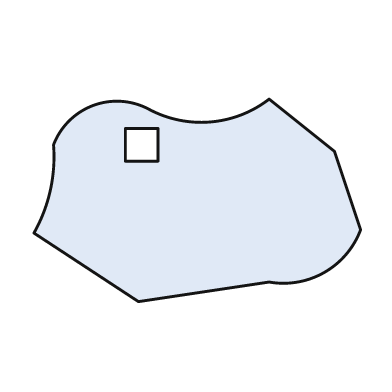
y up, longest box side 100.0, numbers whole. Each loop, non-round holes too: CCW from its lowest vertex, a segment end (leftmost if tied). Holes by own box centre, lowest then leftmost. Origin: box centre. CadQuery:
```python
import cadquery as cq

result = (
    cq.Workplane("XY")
    .moveTo(-18.0, -31.0)
    .lineTo(22.0, -25.0)
    .threePointArc((39.0, -22.0), (50.0, -9.0))
    .lineTo(42.0, 15.0)
    .lineTo(22.0, 31.0)
    .threePointArc((4.0, 24.0), (-15.0, 28.0))
    .threePointArc((-32.0, 29.0), (-44.0, 17.0))
    .threePointArc((-45.0, 3.0), (-50.0, -10.0))
    .close()
    .moveTo(-22.0, 12.0)
    .lineTo(-12.0, 12.0)
    .lineTo(-12.0, 22.0)
    .lineTo(-22.0, 22.0)
    .close()
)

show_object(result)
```